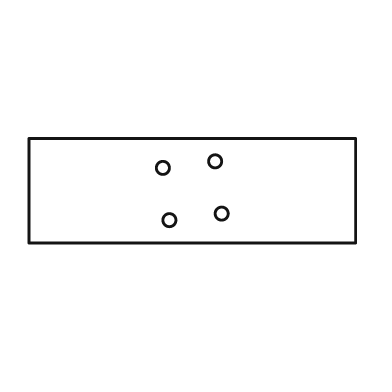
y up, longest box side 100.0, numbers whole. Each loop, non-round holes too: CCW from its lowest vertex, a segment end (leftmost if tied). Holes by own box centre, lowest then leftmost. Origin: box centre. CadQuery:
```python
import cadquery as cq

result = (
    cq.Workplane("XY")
    .moveTo(-50.0, -16.0)
    .lineTo(50.0, -16.0)
    .lineTo(50.0, 16.0)
    .lineTo(-50.0, 16.0)
    .close()
    .moveTo(-7.0, -9.0)
    .circle(2.0)
    .moveTo(9.0, -7.0)
    .circle(2.0)
    .moveTo(-9.0, 7.0)
    .circle(2.0)
    .moveTo(7.0, 9.0)
    .circle(2.0)
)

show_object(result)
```